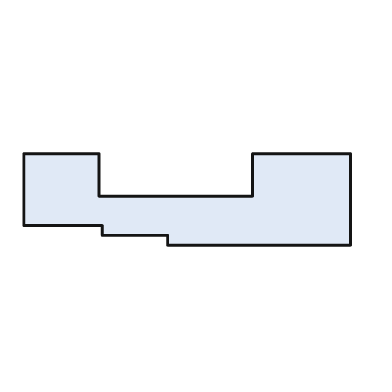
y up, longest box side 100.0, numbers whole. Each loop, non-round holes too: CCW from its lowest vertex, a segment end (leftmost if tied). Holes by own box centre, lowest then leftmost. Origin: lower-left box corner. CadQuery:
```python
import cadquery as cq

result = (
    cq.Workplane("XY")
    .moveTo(44.0, 0.0)
    .lineTo(100.0, 0.0)
    .lineTo(100.0, 28.0)
    .lineTo(70.0, 28.0)
    .lineTo(70.0, 15.0)
    .lineTo(23.0, 15.0)
    .lineTo(23.0, 28.0)
    .lineTo(0.0, 28.0)
    .lineTo(0.0, 6.0)
    .lineTo(24.0, 6.0)
    .lineTo(24.0, 3.0)
    .lineTo(44.0, 3.0)
    .close()
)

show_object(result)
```